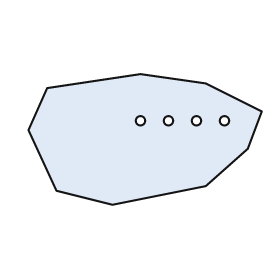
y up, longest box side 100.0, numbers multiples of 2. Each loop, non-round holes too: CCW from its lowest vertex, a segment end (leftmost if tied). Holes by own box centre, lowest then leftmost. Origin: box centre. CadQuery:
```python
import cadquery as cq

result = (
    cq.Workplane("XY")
    .moveTo(-14.0, -28.0)
    .lineTo(26.0, -20.0)
    .lineTo(44.0, -4.0)
    .lineTo(50.0, 12.0)
    .lineTo(26.0, 24.0)
    .lineTo(-2.0, 28.0)
    .lineTo(-42.0, 22.0)
    .lineTo(-50.0, 4.0)
    .lineTo(-38.0, -22.0)
    .close()
    .moveTo(-2.0, 8.0)
    .circle(2.0)
    .moveTo(10.0, 8.0)
    .circle(2.0)
    .moveTo(22.0, 8.0)
    .circle(2.0)
    .moveTo(34.0, 8.0)
    .circle(2.0)
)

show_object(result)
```